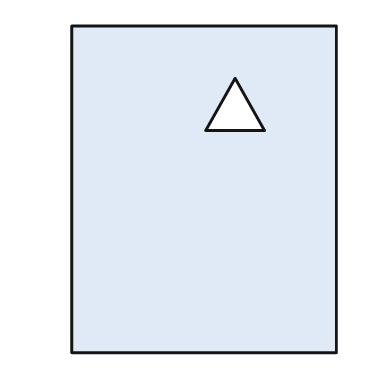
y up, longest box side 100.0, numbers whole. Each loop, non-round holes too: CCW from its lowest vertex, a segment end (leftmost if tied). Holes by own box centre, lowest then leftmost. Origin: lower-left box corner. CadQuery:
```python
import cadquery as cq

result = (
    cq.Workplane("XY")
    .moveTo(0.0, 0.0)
    .lineTo(81.0, 0.0)
    .lineTo(81.0, 100.0)
    .lineTo(0.0, 100.0)
    .close()
    .moveTo(41.0, 68.0)
    .lineTo(59.0, 68.0)
    .lineTo(50.0, 84.0)
    .close()
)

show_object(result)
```